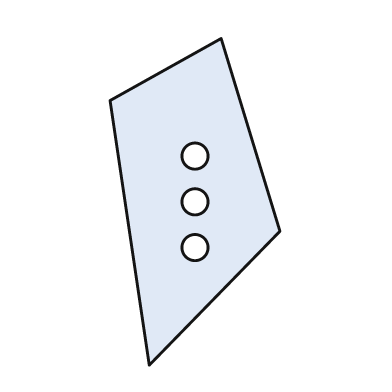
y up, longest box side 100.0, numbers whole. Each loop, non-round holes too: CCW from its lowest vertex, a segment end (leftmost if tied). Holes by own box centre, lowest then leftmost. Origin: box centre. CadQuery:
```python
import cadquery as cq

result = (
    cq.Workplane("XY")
    .moveTo(-14.0, -50.0)
    .lineTo(26.0, -9.0)
    .lineTo(8.0, 50.0)
    .lineTo(-26.0, 31.0)
    .close()
    .moveTo(0.0, -14.0)
    .circle(4.0)
    .moveTo(0.0, 0.0)
    .circle(4.0)
    .moveTo(0.0, 14.0)
    .circle(4.0)
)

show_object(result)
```